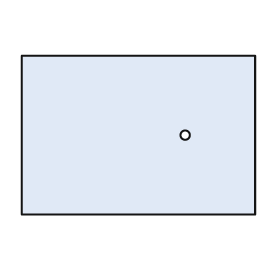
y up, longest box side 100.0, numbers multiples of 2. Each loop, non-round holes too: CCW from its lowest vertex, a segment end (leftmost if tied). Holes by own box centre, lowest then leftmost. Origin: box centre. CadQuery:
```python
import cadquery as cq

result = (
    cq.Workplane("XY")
    .moveTo(-50.0, -34.0)
    .lineTo(50.0, -34.0)
    .lineTo(50.0, 34.0)
    .lineTo(-50.0, 34.0)
    .close()
    .moveTo(20.0, 0.0)
    .circle(2.0)
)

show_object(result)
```